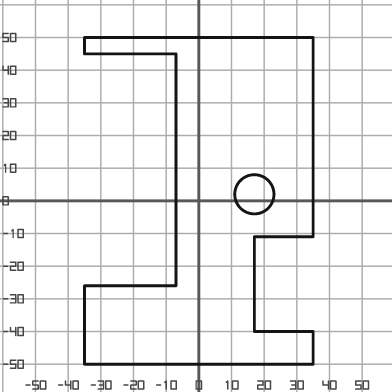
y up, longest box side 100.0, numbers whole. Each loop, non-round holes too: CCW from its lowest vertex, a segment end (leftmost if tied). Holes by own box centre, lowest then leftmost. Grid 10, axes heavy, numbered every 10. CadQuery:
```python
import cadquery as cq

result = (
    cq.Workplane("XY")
    .moveTo(-35.0, -50.0)
    .lineTo(35.0, -50.0)
    .lineTo(35.0, -40.0)
    .lineTo(17.0, -40.0)
    .lineTo(17.0, -11.0)
    .lineTo(35.0, -11.0)
    .lineTo(35.0, 50.0)
    .lineTo(-35.0, 50.0)
    .lineTo(-35.0, 45.0)
    .lineTo(-7.0, 45.0)
    .lineTo(-7.0, -26.0)
    .lineTo(-35.0, -26.0)
    .close()
    .moveTo(17.0, 2.0)
    .circle(6.0)
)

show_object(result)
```